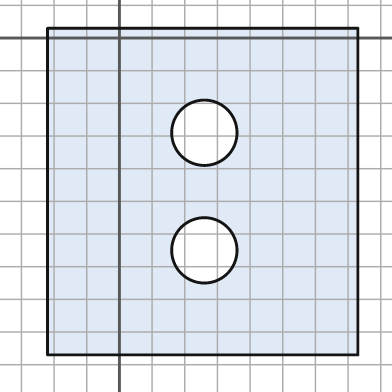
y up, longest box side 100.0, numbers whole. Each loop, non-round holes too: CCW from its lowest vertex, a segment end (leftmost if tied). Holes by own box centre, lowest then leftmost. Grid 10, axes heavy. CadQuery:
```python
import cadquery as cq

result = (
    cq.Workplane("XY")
    .moveTo(-22.0, -97.0)
    .lineTo(73.0, -97.0)
    .lineTo(73.0, 3.0)
    .lineTo(-22.0, 3.0)
    .close()
    .moveTo(26.0, -65.0)
    .circle(10.0)
    .moveTo(26.0, -29.0)
    .circle(10.0)
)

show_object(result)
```